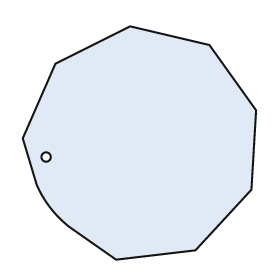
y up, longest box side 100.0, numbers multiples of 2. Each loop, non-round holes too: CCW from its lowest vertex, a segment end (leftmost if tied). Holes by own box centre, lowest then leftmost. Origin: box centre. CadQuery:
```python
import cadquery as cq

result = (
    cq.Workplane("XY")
    .moveTo(-10.0, -50.0)
    .lineTo(24.0, -46.0)
    .lineTo(48.0, -20.0)
    .lineTo(50.0, 14.0)
    .lineTo(30.0, 42.0)
    .lineTo(-4.0, 50.0)
    .lineTo(-36.0, 34.0)
    .lineTo(-50.0, 2.0)
    .lineTo(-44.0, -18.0)
    .threePointArc((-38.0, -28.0), (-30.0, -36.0))
    .close()
    .moveTo(-40.0, -6.0)
    .circle(2.0)
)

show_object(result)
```